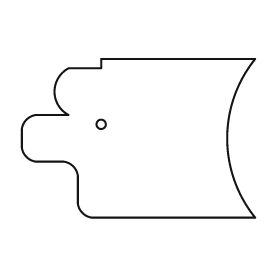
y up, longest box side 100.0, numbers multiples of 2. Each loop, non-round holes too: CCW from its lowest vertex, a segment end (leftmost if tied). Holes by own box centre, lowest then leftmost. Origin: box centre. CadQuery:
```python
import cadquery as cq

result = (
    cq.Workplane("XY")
    .moveTo(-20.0, -34.0)
    .lineTo(50.0, -34.0)
    .threePointArc((38.0, 0.0), (50.0, 34.0))
    .lineTo(-16.0, 34.0)
    .lineTo(-16.0, 30.0)
    .lineTo(-30.0, 30.0)
    .threePointArc((-36.0, 20.0), (-30.0, 10.0))
    .lineTo(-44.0, 10.0)
    .threePointArc((-48.0, 8.0), (-50.0, 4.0))
    .lineTo(-50.0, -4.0)
    .threePointArc((-48.0, -8.0), (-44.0, -10.0))
    .lineTo(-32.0, -10.0)
    .threePointArc((-28.0, -12.0), (-26.0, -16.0))
    .lineTo(-26.0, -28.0)
    .threePointArc((-24.0, -32.0), (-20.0, -34.0))
    .close()
    .moveTo(-16.0, 6.0)
    .circle(2.0)
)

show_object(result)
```